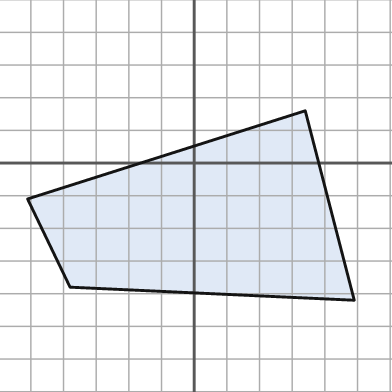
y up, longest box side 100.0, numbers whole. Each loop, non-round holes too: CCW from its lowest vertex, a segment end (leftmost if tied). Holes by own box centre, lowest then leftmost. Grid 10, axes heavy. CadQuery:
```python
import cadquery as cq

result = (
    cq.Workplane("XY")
    .moveTo(49.0, -42.0)
    .lineTo(34.0, 16.0)
    .lineTo(-51.0, -11.0)
    .lineTo(-38.0, -38.0)
    .close()
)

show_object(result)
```